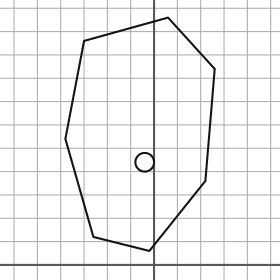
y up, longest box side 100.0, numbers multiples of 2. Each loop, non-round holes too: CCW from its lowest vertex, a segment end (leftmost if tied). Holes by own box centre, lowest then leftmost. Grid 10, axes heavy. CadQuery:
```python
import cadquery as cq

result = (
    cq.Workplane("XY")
    .moveTo(-2.0, 6.0)
    .lineTo(22.0, 36.0)
    .lineTo(26.0, 84.0)
    .lineTo(6.0, 106.0)
    .lineTo(-30.0, 96.0)
    .lineTo(-38.0, 54.0)
    .lineTo(-26.0, 12.0)
    .close()
    .moveTo(-4.0, 44.0)
    .circle(4.0)
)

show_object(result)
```